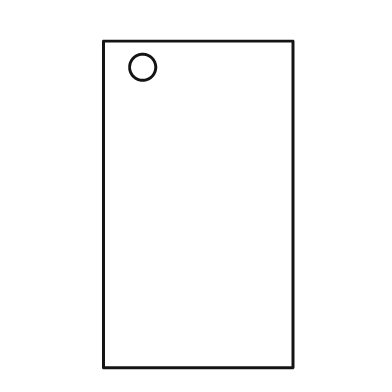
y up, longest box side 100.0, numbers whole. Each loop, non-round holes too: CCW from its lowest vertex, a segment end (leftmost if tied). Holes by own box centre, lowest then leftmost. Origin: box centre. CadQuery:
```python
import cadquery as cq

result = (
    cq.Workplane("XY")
    .moveTo(-29.0, -50.0)
    .lineTo(29.0, -50.0)
    .lineTo(29.0, 50.0)
    .lineTo(-29.0, 50.0)
    .close()
    .moveTo(-17.0, 42.0)
    .circle(4.0)
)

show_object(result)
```